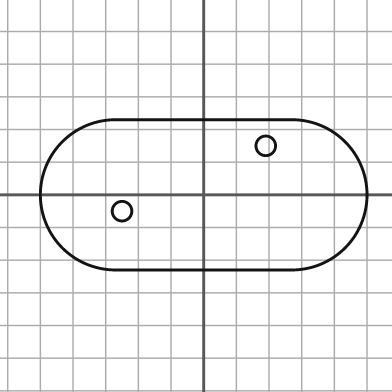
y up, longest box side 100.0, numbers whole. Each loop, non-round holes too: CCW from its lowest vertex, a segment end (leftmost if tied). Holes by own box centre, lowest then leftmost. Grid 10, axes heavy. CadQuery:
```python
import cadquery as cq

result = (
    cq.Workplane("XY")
    .moveTo(-27.0, -23.0)
    .lineTo(27.0, -23.0)
    .threePointArc((50.0, 0.0), (27.0, 23.0))
    .lineTo(-27.0, 23.0)
    .threePointArc((-50.0, 0.0), (-27.0, -23.0))
    .close()
    .moveTo(-25.0, -5.0)
    .circle(3.0)
    .moveTo(19.0, 15.0)
    .circle(3.0)
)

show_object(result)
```